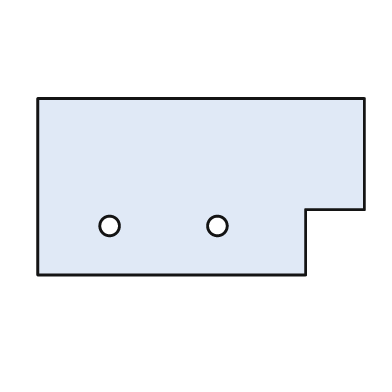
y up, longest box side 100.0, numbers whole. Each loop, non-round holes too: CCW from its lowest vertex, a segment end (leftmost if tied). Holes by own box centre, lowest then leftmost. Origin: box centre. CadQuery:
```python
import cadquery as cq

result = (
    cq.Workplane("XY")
    .moveTo(-50.0, -27.0)
    .lineTo(32.0, -27.0)
    .lineTo(32.0, -7.0)
    .lineTo(50.0, -7.0)
    .lineTo(50.0, 27.0)
    .lineTo(-50.0, 27.0)
    .close()
    .moveTo(-28.0, -12.0)
    .circle(3.0)
    .moveTo(5.0, -12.0)
    .circle(3.0)
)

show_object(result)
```